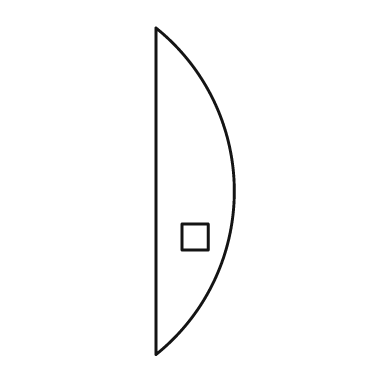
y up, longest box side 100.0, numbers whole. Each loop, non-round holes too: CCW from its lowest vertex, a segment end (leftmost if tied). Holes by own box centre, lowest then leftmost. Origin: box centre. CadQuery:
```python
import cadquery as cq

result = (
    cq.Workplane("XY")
    .moveTo(-12.0, -50.0)
    .threePointArc((12.0, 0.0), (-12.0, 50.0))
    .close()
    .moveTo(-4.0, -18.0)
    .lineTo(4.0, -18.0)
    .lineTo(4.0, -10.0)
    .lineTo(-4.0, -10.0)
    .close()
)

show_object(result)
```